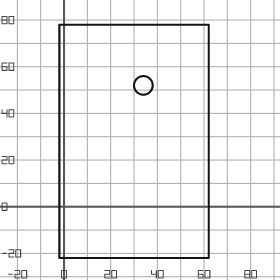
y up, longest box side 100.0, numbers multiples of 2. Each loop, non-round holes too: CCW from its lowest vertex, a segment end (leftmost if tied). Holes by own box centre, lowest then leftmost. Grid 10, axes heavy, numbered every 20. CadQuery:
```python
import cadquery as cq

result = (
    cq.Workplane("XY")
    .moveTo(-2.0, -22.0)
    .lineTo(62.0, -22.0)
    .lineTo(62.0, 78.0)
    .lineTo(-2.0, 78.0)
    .close()
    .moveTo(34.0, 52.0)
    .circle(4.0)
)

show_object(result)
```